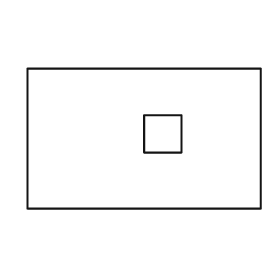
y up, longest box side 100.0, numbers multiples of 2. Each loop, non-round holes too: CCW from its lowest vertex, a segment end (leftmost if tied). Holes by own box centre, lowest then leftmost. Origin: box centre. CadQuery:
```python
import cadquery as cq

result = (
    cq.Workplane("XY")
    .moveTo(-50.0, -30.0)
    .lineTo(50.0, -30.0)
    .lineTo(50.0, 30.0)
    .lineTo(-50.0, 30.0)
    .close()
    .moveTo(0.0, -6.0)
    .lineTo(16.0, -6.0)
    .lineTo(16.0, 10.0)
    .lineTo(0.0, 10.0)
    .close()
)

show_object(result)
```